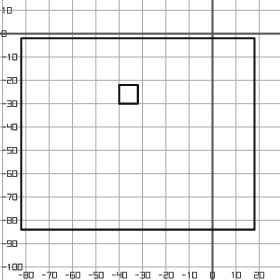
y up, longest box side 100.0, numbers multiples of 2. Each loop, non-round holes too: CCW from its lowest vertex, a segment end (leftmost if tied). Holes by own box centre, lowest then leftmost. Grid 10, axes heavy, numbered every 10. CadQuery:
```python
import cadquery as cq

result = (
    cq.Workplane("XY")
    .moveTo(-82.0, -84.0)
    .lineTo(18.0, -84.0)
    .lineTo(18.0, -2.0)
    .lineTo(-82.0, -2.0)
    .close()
    .moveTo(-40.0, -30.0)
    .lineTo(-32.0, -30.0)
    .lineTo(-32.0, -22.0)
    .lineTo(-40.0, -22.0)
    .close()
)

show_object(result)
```